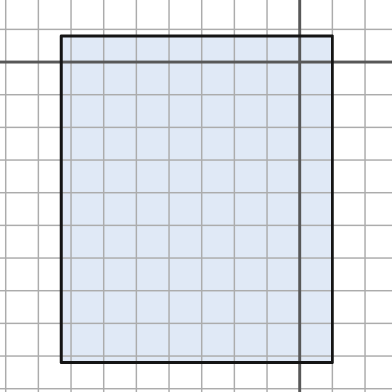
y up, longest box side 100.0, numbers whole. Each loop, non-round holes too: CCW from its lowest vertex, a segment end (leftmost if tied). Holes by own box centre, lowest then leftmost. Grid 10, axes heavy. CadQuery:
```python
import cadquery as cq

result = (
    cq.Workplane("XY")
    .moveTo(-73.0, -92.0)
    .lineTo(10.0, -92.0)
    .lineTo(10.0, 8.0)
    .lineTo(-73.0, 8.0)
    .close()
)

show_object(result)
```